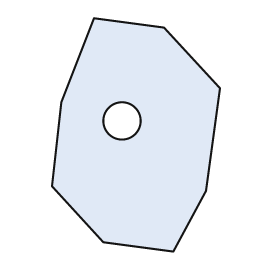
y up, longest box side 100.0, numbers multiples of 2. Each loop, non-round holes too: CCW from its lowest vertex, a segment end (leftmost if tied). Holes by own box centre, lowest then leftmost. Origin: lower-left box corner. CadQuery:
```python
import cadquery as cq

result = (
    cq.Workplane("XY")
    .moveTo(52.0, 0.0)
    .lineTo(66.0, 26.0)
    .lineTo(72.0, 70.0)
    .lineTo(48.0, 96.0)
    .lineTo(18.0, 100.0)
    .lineTo(4.0, 64.0)
    .lineTo(0.0, 28.0)
    .lineTo(22.0, 4.0)
    .close()
    .moveTo(30.0, 56.0)
    .circle(8.0)
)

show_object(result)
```